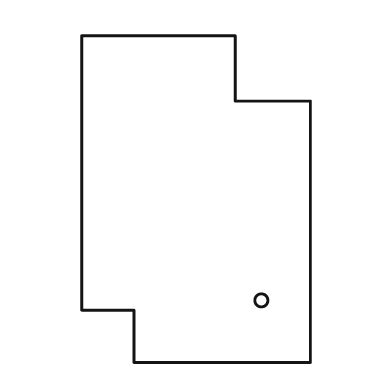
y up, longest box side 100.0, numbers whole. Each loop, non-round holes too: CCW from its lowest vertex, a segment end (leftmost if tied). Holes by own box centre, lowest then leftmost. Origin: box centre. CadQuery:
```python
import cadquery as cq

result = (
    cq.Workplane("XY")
    .moveTo(-19.0, -50.0)
    .lineTo(35.0, -50.0)
    .lineTo(35.0, 30.0)
    .lineTo(12.0, 30.0)
    .lineTo(12.0, 50.0)
    .lineTo(-35.0, 50.0)
    .lineTo(-35.0, -34.0)
    .lineTo(-19.0, -34.0)
    .close()
    .moveTo(20.0, -31.0)
    .circle(2.0)
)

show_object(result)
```